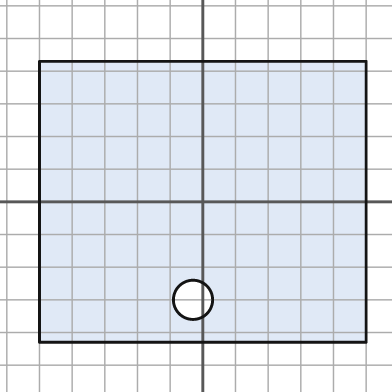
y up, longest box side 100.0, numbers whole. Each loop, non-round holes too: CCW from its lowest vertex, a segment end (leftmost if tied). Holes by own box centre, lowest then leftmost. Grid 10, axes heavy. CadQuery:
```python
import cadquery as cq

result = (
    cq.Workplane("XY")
    .moveTo(-50.0, -43.0)
    .lineTo(50.0, -43.0)
    .lineTo(50.0, 43.0)
    .lineTo(-50.0, 43.0)
    .close()
    .moveTo(-3.0, -30.0)
    .circle(6.0)
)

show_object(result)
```